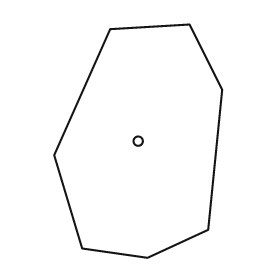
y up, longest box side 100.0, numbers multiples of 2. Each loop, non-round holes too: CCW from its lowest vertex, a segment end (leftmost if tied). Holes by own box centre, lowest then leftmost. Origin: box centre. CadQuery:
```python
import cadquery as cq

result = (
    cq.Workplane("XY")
    .moveTo(4.0, -50.0)
    .lineTo(30.0, -38.0)
    .lineTo(36.0, 22.0)
    .lineTo(22.0, 50.0)
    .lineTo(-12.0, 48.0)
    .lineTo(-36.0, -6.0)
    .lineTo(-24.0, -46.0)
    .close()
    .moveTo(0.0, 0.0)
    .circle(2.0)
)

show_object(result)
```